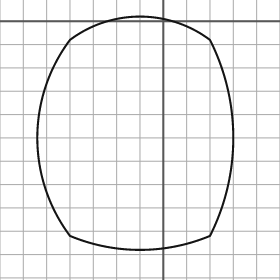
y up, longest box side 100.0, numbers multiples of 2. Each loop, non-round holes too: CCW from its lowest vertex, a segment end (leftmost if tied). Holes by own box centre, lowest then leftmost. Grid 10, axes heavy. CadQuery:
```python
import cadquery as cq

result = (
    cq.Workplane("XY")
    .moveTo(-40.0, -92.0)
    .threePointArc((-10.0, -98.0), (20.0, -92.0))
    .threePointArc((30.0, -50.0), (20.0, -8.0))
    .threePointArc((-10.0, 2.0), (-40.0, -8.0))
    .threePointArc((-54.0, -50.0), (-40.0, -92.0))
    .close()
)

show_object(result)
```